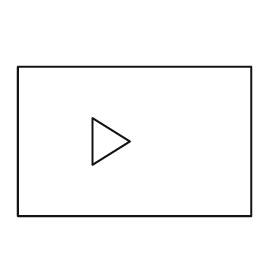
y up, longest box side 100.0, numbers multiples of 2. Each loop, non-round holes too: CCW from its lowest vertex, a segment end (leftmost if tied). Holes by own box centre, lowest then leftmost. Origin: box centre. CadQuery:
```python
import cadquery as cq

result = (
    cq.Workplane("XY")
    .moveTo(-50.0, -32.0)
    .lineTo(50.0, -32.0)
    .lineTo(50.0, 32.0)
    .lineTo(-50.0, 32.0)
    .close()
    .moveTo(-18.0, -10.0)
    .lineTo(-2.0, 0.0)
    .lineTo(-18.0, 10.0)
    .close()
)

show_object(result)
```